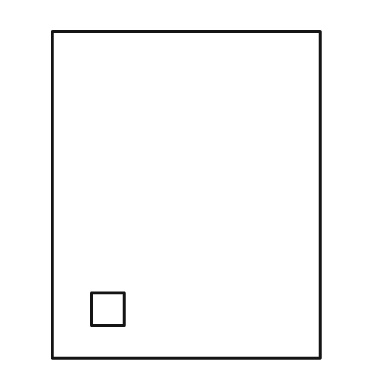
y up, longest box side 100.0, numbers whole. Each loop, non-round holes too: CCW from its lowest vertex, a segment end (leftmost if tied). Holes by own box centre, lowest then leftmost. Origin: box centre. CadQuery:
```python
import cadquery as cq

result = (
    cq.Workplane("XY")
    .moveTo(-41.0, -50.0)
    .lineTo(41.0, -50.0)
    .lineTo(41.0, 50.0)
    .lineTo(-41.0, 50.0)
    .close()
    .moveTo(-29.0, -40.0)
    .lineTo(-19.0, -40.0)
    .lineTo(-19.0, -30.0)
    .lineTo(-29.0, -30.0)
    .close()
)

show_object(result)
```